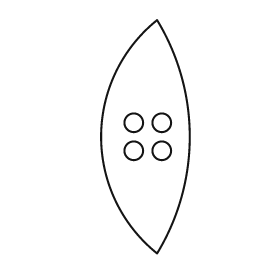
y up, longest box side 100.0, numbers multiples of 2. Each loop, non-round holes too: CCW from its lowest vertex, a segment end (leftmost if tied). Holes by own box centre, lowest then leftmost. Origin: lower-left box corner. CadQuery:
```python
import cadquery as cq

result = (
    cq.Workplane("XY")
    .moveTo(24.0, 0.0)
    .threePointArc((38.0, 50.0), (24.0, 100.0))
    .threePointArc((0.0, 50.0), (24.0, 0.0))
    .close()
    .moveTo(14.0, 44.0)
    .circle(4.0)
    .moveTo(26.0, 44.0)
    .circle(4.0)
    .moveTo(14.0, 56.0)
    .circle(4.0)
    .moveTo(26.0, 56.0)
    .circle(4.0)
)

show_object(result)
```